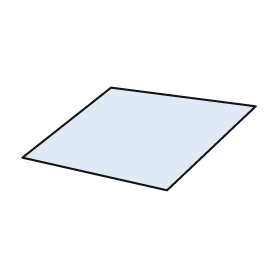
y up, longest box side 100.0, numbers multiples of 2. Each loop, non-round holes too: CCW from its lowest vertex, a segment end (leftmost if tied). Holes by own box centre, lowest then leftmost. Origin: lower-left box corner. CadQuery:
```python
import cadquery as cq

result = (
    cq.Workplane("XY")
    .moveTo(62.0, 0.0)
    .lineTo(100.0, 36.0)
    .lineTo(38.0, 44.0)
    .lineTo(0.0, 14.0)
    .close()
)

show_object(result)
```